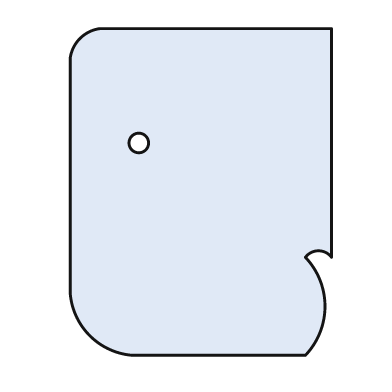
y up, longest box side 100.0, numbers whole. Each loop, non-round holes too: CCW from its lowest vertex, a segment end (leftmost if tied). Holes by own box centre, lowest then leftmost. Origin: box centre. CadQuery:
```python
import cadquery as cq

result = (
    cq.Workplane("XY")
    .moveTo(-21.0, -50.0)
    .lineTo(32.0, -50.0)
    .threePointArc((38.0, -35.0), (32.0, -20.0))
    .threePointArc((36.0, -18.0), (40.0, -20.0))
    .lineTo(40.0, 50.0)
    .lineTo(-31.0, 50.0)
    .threePointArc((-37.0, 47.0), (-40.0, 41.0))
    .lineTo(-40.0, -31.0)
    .threePointArc((-34.0, -44.0), (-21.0, -50.0))
    .close()
    .moveTo(-19.0, 15.0)
    .circle(3.0)
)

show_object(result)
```